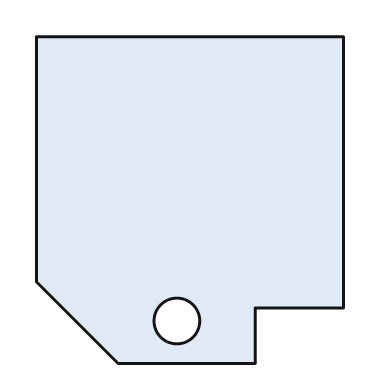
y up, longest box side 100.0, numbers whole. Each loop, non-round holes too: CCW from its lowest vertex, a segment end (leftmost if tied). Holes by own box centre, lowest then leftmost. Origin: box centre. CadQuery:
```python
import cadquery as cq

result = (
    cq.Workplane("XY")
    .moveTo(-22.0, -50.0)
    .lineTo(20.0, -50.0)
    .lineTo(20.0, -33.0)
    .lineTo(47.0, -33.0)
    .lineTo(47.0, 50.0)
    .lineTo(-47.0, 50.0)
    .lineTo(-47.0, -25.0)
    .close()
    .moveTo(-4.0, -37.0)
    .circle(7.0)
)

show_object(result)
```